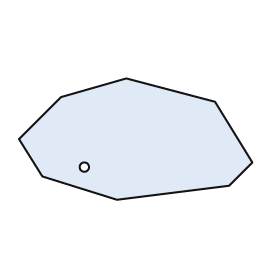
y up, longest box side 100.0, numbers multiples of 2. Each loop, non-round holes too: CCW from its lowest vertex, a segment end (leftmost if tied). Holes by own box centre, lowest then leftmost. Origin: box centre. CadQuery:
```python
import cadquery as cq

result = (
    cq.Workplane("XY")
    .moveTo(-8.0, -26.0)
    .lineTo(40.0, -20.0)
    .lineTo(50.0, -10.0)
    .lineTo(34.0, 16.0)
    .lineTo(-4.0, 26.0)
    .lineTo(-32.0, 18.0)
    .lineTo(-50.0, 0.0)
    .lineTo(-40.0, -16.0)
    .close()
    .moveTo(-22.0, -12.0)
    .circle(2.0)
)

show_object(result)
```